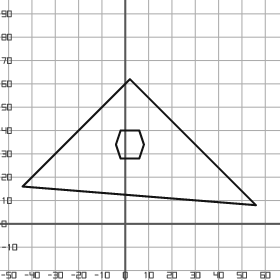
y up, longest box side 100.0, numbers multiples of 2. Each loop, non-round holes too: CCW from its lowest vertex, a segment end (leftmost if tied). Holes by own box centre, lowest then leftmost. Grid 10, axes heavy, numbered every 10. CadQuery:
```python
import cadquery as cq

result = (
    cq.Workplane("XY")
    .moveTo(56.0, 8.0)
    .lineTo(2.0, 62.0)
    .lineTo(-44.0, 16.0)
    .close()
    .moveTo(-2.0, 28.0)
    .lineTo(6.0, 28.0)
    .lineTo(8.0, 34.0)
    .lineTo(6.0, 40.0)
    .lineTo(-2.0, 40.0)
    .lineTo(-4.0, 34.0)
    .close()
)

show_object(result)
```